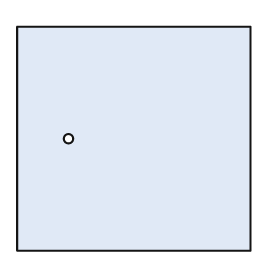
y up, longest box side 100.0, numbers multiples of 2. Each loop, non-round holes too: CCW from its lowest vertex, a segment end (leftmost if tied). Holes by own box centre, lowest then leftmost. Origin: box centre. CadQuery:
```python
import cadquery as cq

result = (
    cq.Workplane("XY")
    .moveTo(-50.0, -48.0)
    .lineTo(50.0, -48.0)
    .lineTo(50.0, 48.0)
    .lineTo(-50.0, 48.0)
    .close()
    .moveTo(-28.0, 0.0)
    .circle(2.0)
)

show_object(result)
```